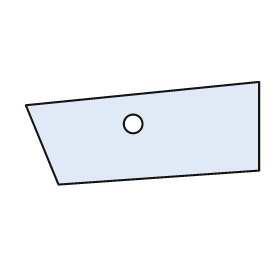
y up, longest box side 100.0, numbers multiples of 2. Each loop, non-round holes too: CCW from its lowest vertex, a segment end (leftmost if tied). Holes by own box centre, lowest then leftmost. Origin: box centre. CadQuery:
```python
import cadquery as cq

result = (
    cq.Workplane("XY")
    .moveTo(-36.0, -22.0)
    .lineTo(50.0, -16.0)
    .lineTo(50.0, 22.0)
    .lineTo(-50.0, 12.0)
    .close()
    .moveTo(-4.0, 4.0)
    .circle(4.0)
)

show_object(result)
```